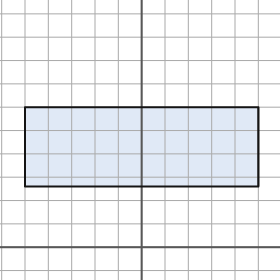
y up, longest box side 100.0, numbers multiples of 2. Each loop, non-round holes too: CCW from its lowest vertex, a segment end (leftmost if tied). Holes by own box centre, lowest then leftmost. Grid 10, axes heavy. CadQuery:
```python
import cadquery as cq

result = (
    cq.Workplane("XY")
    .moveTo(-50.0, 26.0)
    .lineTo(50.0, 26.0)
    .lineTo(50.0, 60.0)
    .lineTo(-50.0, 60.0)
    .close()
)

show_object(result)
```